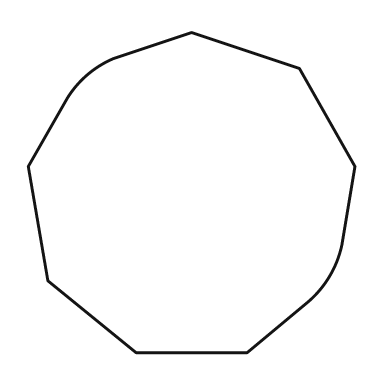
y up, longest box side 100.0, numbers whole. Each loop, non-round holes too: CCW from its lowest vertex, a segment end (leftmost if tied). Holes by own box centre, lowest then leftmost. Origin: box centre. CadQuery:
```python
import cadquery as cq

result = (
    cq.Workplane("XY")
    .moveTo(-17.0, -49.0)
    .lineTo(17.0, -49.0)
    .lineTo(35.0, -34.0)
    .threePointArc((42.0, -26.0), (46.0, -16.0))
    .lineTo(50.0, 8.0)
    .lineTo(33.0, 38.0)
    .lineTo(0.0, 49.0)
    .lineTo(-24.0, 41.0)
    .threePointArc((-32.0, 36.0), (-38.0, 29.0))
    .lineTo(-50.0, 8.0)
    .lineTo(-44.0, -27.0)
    .close()
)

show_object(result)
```